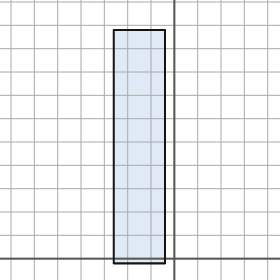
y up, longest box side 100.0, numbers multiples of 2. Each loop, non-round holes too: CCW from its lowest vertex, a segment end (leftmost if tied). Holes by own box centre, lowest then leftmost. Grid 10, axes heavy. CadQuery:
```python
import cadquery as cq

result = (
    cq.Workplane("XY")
    .moveTo(-26.0, -2.0)
    .lineTo(-4.0, -2.0)
    .lineTo(-4.0, 98.0)
    .lineTo(-26.0, 98.0)
    .close()
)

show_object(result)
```